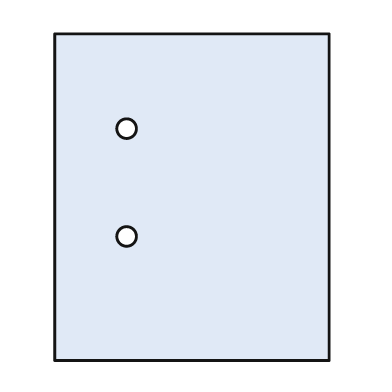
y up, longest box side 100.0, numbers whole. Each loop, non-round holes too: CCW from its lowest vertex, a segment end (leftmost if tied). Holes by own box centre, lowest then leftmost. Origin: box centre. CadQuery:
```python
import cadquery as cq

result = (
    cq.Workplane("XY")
    .moveTo(-42.0, -50.0)
    .lineTo(42.0, -50.0)
    .lineTo(42.0, 50.0)
    .lineTo(-42.0, 50.0)
    .close()
    .moveTo(-20.0, -12.0)
    .circle(3.0)
    .moveTo(-20.0, 21.0)
    .circle(3.0)
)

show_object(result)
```